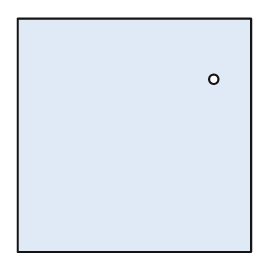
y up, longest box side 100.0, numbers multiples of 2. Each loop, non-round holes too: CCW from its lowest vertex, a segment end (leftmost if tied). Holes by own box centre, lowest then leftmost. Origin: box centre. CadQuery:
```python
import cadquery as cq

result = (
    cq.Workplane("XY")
    .moveTo(-50.0, -50.0)
    .lineTo(50.0, -50.0)
    .lineTo(50.0, 50.0)
    .lineTo(-50.0, 50.0)
    .close()
    .moveTo(34.0, 24.0)
    .circle(2.0)
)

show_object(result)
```